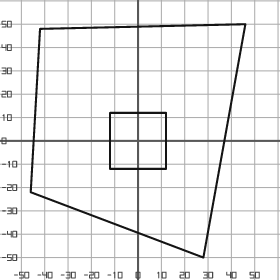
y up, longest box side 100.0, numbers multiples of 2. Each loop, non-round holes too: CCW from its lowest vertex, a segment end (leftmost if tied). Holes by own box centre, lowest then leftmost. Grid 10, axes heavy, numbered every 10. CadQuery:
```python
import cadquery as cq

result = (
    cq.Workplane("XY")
    .moveTo(28.0, -50.0)
    .lineTo(46.0, 50.0)
    .lineTo(-42.0, 48.0)
    .lineTo(-46.0, -22.0)
    .close()
    .moveTo(-12.0, -12.0)
    .lineTo(12.0, -12.0)
    .lineTo(12.0, 12.0)
    .lineTo(-12.0, 12.0)
    .close()
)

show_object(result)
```